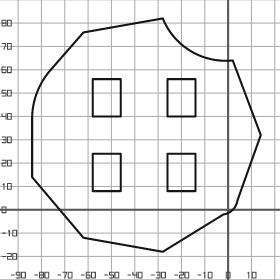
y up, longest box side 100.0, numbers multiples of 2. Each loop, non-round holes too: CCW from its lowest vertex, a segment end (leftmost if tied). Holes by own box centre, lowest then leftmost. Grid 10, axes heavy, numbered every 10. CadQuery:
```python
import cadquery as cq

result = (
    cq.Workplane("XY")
    .moveTo(-28.0, -18.0)
    .lineTo(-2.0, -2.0)
    .threePointArc((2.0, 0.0), (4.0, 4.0))
    .lineTo(14.0, 32.0)
    .lineTo(2.0, 64.0)
    .threePointArc((-16.0, 68.0), (-28.0, 82.0))
    .lineTo(-62.0, 76.0)
    .lineTo(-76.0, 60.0)
    .threePointArc((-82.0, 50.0), (-84.0, 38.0))
    .lineTo(-84.0, 14.0)
    .lineTo(-62.0, -12.0)
    .close()
    .moveTo(-58.0, 8.0)
    .lineTo(-46.0, 8.0)
    .lineTo(-46.0, 24.0)
    .lineTo(-58.0, 24.0)
    .close()
    .moveTo(-26.0, 8.0)
    .lineTo(-14.0, 8.0)
    .lineTo(-14.0, 24.0)
    .lineTo(-26.0, 24.0)
    .close()
    .moveTo(-58.0, 40.0)
    .lineTo(-46.0, 40.0)
    .lineTo(-46.0, 56.0)
    .lineTo(-58.0, 56.0)
    .close()
    .moveTo(-26.0, 40.0)
    .lineTo(-14.0, 40.0)
    .lineTo(-14.0, 56.0)
    .lineTo(-26.0, 56.0)
    .close()
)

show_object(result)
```